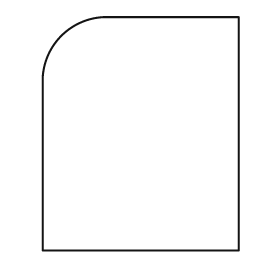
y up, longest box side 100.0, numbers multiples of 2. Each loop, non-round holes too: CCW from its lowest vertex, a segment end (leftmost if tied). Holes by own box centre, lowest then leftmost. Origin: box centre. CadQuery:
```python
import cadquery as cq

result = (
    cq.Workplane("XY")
    .moveTo(-42.0, -50.0)
    .lineTo(42.0, -50.0)
    .lineTo(42.0, 50.0)
    .lineTo(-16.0, 50.0)
    .threePointArc((-34.0, 42.0), (-42.0, 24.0))
    .close()
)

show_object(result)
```